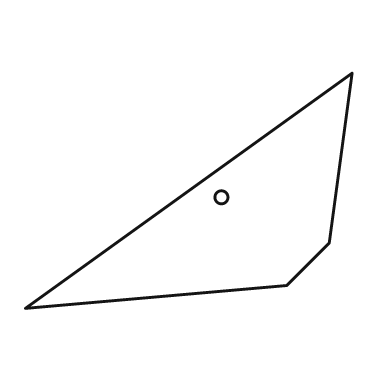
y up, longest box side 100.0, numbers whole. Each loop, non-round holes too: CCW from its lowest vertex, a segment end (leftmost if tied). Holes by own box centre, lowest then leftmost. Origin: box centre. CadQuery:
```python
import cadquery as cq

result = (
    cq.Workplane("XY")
    .moveTo(-50.0, -36.0)
    .lineTo(30.0, -29.0)
    .lineTo(43.0, -16.0)
    .lineTo(50.0, 36.0)
    .close()
    .moveTo(10.0, -2.0)
    .circle(2.0)
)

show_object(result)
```